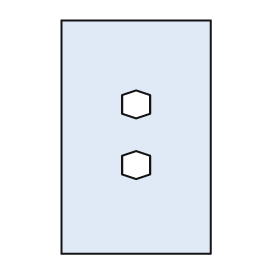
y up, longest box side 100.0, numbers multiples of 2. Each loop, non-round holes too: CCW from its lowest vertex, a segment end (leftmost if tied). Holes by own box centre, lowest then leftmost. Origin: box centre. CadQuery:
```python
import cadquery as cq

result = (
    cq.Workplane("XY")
    .moveTo(-32.0, -50.0)
    .lineTo(32.0, -50.0)
    .lineTo(32.0, 50.0)
    .lineTo(-32.0, 50.0)
    .close()
    .moveTo(0.0, -18.0)
    .lineTo(6.0, -16.0)
    .lineTo(6.0, -8.0)
    .lineTo(0.0, -6.0)
    .lineTo(-6.0, -8.0)
    .lineTo(-6.0, -16.0)
    .close()
    .moveTo(0.0, 8.0)
    .lineTo(6.0, 10.0)
    .lineTo(6.0, 18.0)
    .lineTo(0.0, 20.0)
    .lineTo(-6.0, 18.0)
    .lineTo(-6.0, 10.0)
    .close()
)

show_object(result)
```